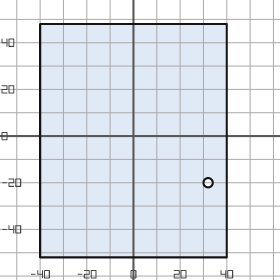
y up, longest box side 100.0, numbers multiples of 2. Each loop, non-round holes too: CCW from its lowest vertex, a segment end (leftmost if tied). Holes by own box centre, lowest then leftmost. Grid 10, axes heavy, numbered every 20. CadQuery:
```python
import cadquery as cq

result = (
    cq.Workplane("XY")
    .moveTo(-40.0, -52.0)
    .lineTo(40.0, -52.0)
    .lineTo(40.0, 48.0)
    .lineTo(-40.0, 48.0)
    .close()
    .moveTo(32.0, -20.0)
    .circle(2.0)
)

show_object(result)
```